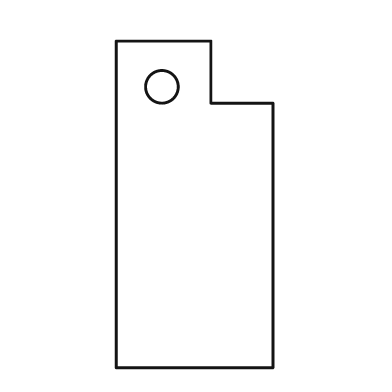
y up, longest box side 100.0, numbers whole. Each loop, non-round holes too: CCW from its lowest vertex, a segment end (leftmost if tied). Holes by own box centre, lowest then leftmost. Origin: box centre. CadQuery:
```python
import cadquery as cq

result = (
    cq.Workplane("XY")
    .moveTo(-24.0, -50.0)
    .lineTo(24.0, -50.0)
    .lineTo(24.0, 31.0)
    .lineTo(5.0, 31.0)
    .lineTo(5.0, 50.0)
    .lineTo(-24.0, 50.0)
    .close()
    .moveTo(-10.0, 36.0)
    .circle(5.0)
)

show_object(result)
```